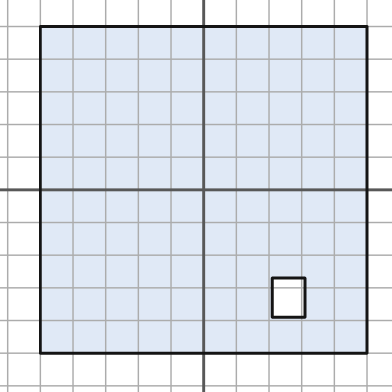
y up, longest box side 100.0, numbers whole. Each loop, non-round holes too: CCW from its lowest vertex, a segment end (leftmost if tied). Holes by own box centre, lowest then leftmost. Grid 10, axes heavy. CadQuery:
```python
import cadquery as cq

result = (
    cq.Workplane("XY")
    .moveTo(-50.0, -50.0)
    .lineTo(50.0, -50.0)
    .lineTo(50.0, 50.0)
    .lineTo(-50.0, 50.0)
    .close()
    .moveTo(21.0, -39.0)
    .lineTo(31.0, -39.0)
    .lineTo(31.0, -27.0)
    .lineTo(21.0, -27.0)
    .close()
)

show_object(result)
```